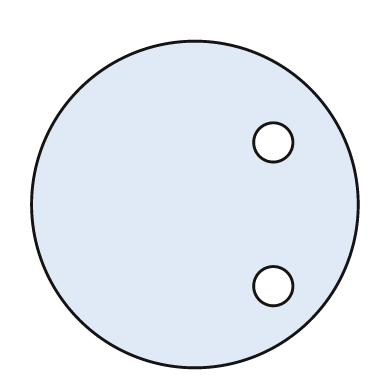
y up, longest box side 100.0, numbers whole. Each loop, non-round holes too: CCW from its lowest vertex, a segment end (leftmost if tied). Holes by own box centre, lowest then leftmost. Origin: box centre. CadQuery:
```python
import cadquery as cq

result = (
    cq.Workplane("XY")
    .moveTo(0.0, 0.0)
    .circle(50.0)
    .moveTo(24.0, -25.0)
    .circle(6.0)
    .moveTo(24.0, 19.0)
    .circle(6.0)
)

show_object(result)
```